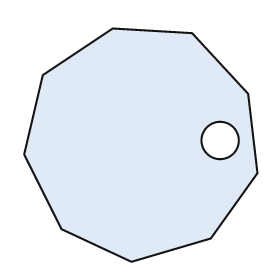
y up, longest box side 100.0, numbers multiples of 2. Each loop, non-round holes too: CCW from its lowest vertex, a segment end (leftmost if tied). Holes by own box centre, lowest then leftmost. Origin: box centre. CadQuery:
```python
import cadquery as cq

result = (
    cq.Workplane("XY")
    .moveTo(-4.0, -50.0)
    .lineTo(30.0, -40.0)
    .lineTo(50.0, -12.0)
    .lineTo(46.0, 22.0)
    .lineTo(22.0, 48.0)
    .lineTo(-12.0, 50.0)
    .lineTo(-42.0, 30.0)
    .lineTo(-50.0, -4.0)
    .lineTo(-34.0, -36.0)
    .close()
    .moveTo(34.0, 2.0)
    .circle(8.0)
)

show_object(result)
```